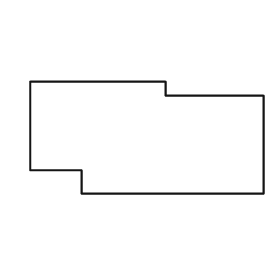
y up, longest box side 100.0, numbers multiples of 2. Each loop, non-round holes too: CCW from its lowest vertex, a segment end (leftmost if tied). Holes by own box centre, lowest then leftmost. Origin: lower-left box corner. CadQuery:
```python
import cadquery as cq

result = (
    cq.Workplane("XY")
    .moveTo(22.0, 0.0)
    .lineTo(100.0, 0.0)
    .lineTo(100.0, 42.0)
    .lineTo(58.0, 42.0)
    .lineTo(58.0, 48.0)
    .lineTo(0.0, 48.0)
    .lineTo(0.0, 10.0)
    .lineTo(22.0, 10.0)
    .close()
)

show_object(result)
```